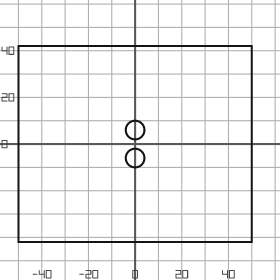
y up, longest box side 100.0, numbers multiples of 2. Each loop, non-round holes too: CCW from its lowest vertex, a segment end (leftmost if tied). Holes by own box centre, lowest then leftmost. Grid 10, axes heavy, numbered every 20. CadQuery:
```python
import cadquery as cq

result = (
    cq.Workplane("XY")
    .moveTo(-50.0, -42.0)
    .lineTo(50.0, -42.0)
    .lineTo(50.0, 42.0)
    .lineTo(-50.0, 42.0)
    .close()
    .moveTo(0.0, -6.0)
    .circle(4.0)
    .moveTo(0.0, 6.0)
    .circle(4.0)
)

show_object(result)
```